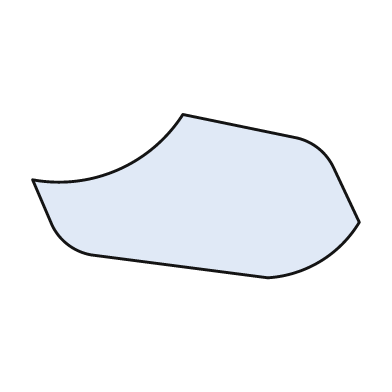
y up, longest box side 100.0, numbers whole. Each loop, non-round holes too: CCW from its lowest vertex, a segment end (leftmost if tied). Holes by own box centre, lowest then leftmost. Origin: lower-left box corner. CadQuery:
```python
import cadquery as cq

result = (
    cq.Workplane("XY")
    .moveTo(72.0, 0.0)
    .threePointArc((88.0, 5.0), (100.0, 17.0))
    .lineTo(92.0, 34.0)
    .threePointArc((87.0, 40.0), (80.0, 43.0))
    .lineTo(46.0, 50.0)
    .threePointArc((26.0, 33.0), (0.0, 30.0))
    .lineTo(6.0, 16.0)
    .threePointArc((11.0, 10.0), (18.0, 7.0))
    .close()
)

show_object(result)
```